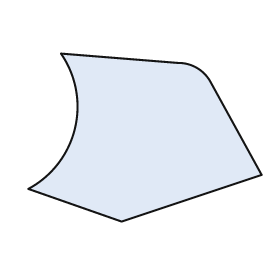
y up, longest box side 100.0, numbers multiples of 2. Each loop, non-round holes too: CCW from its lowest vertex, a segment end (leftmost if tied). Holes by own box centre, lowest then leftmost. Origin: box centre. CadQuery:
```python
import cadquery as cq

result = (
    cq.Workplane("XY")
    .moveTo(-10.0, -36.0)
    .lineTo(50.0, -16.0)
    .lineTo(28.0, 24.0)
    .threePointArc((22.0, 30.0), (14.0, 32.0))
    .lineTo(-36.0, 36.0)
    .threePointArc((-30.0, 4.0), (-50.0, -22.0))
    .close()
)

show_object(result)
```